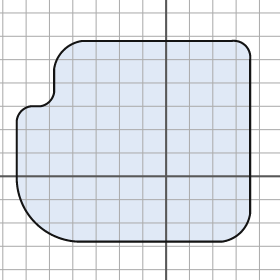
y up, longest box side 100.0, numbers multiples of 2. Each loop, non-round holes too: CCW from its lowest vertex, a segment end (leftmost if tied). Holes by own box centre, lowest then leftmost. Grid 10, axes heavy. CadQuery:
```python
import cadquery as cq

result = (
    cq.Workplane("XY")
    .moveTo(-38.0, -28.0)
    .lineTo(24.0, -28.0)
    .threePointArc((32.0, -24.0), (36.0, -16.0))
    .lineTo(36.0, 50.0)
    .threePointArc((34.0, 56.0), (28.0, 58.0))
    .lineTo(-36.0, 58.0)
    .threePointArc((-44.0, 54.0), (-48.0, 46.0))
    .lineTo(-48.0, 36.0)
    .threePointArc((-50.0, 32.0), (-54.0, 30.0))
    .lineTo(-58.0, 30.0)
    .threePointArc((-62.0, 28.0), (-64.0, 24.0))
    .lineTo(-64.0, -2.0)
    .threePointArc((-56.0, -20.0), (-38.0, -28.0))
    .close()
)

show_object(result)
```